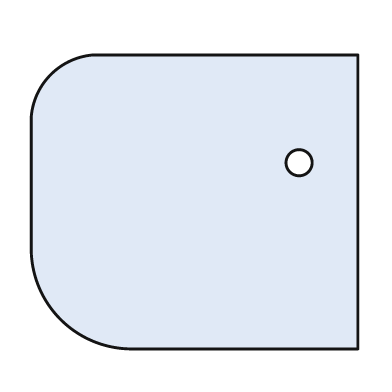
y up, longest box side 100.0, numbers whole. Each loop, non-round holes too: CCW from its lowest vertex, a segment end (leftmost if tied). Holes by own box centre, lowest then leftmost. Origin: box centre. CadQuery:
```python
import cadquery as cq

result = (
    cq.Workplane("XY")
    .moveTo(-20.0, -45.0)
    .lineTo(50.0, -45.0)
    .lineTo(50.0, 45.0)
    .lineTo(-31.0, 45.0)
    .threePointArc((-44.0, 39.0), (-50.0, 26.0))
    .lineTo(-50.0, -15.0)
    .threePointArc((-41.0, -36.0), (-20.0, -45.0))
    .close()
    .moveTo(32.0, 12.0)
    .circle(4.0)
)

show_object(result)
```